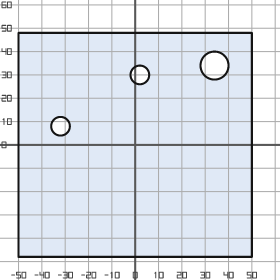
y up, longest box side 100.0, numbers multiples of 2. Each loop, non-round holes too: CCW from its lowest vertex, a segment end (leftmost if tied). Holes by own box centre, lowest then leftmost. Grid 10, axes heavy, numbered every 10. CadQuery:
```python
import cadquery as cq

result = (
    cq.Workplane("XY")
    .moveTo(-50.0, -48.0)
    .lineTo(50.0, -48.0)
    .lineTo(50.0, 48.0)
    .lineTo(-50.0, 48.0)
    .close()
    .moveTo(-32.0, 8.0)
    .circle(4.0)
    .moveTo(2.0, 30.0)
    .circle(4.0)
    .moveTo(34.0, 34.0)
    .circle(6.0)
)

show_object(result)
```